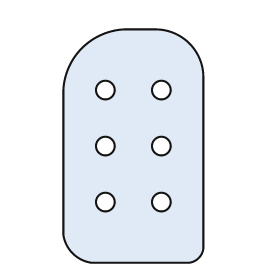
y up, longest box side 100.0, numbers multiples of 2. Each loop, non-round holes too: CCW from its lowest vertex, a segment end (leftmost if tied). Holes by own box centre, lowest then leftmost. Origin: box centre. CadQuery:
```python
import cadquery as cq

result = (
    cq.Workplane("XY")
    .moveTo(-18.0, -50.0)
    .lineTo(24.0, -50.0)
    .threePointArc((28.0, -48.0), (30.0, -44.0))
    .lineTo(30.0, 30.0)
    .threePointArc((24.0, 44.0), (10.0, 50.0))
    .lineTo(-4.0, 50.0)
    .threePointArc((-22.0, 42.0), (-30.0, 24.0))
    .lineTo(-30.0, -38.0)
    .threePointArc((-26.0, -46.0), (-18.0, -50.0))
    .close()
    .moveTo(-12.0, -24.0)
    .circle(4.0)
    .moveTo(12.0, -24.0)
    .circle(4.0)
    .moveTo(-12.0, 0.0)
    .circle(4.0)
    .moveTo(12.0, 0.0)
    .circle(4.0)
    .moveTo(-12.0, 24.0)
    .circle(4.0)
    .moveTo(12.0, 24.0)
    .circle(4.0)
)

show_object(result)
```